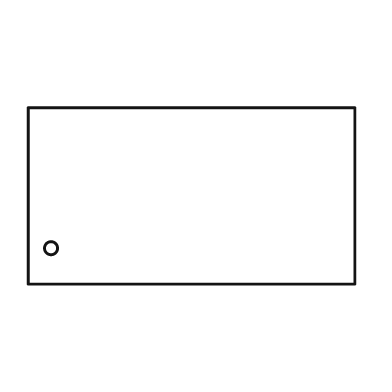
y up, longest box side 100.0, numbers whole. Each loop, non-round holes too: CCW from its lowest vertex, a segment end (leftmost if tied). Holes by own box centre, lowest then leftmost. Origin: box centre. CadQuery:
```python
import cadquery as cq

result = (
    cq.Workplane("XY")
    .moveTo(-50.0, -27.0)
    .lineTo(50.0, -27.0)
    .lineTo(50.0, 27.0)
    .lineTo(-50.0, 27.0)
    .close()
    .moveTo(-43.0, -16.0)
    .circle(2.0)
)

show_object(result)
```